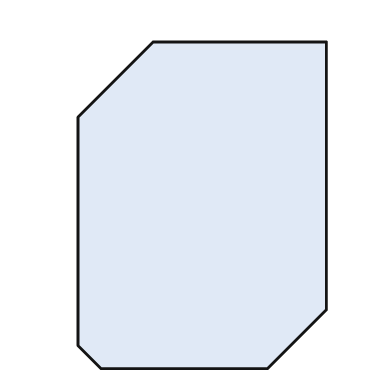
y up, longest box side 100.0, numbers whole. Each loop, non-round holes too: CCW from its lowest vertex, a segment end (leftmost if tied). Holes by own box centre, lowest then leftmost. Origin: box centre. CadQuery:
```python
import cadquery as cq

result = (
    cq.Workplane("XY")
    .moveTo(-31.0, -50.0)
    .lineTo(20.0, -50.0)
    .lineTo(38.0, -32.0)
    .lineTo(38.0, 50.0)
    .lineTo(-15.0, 50.0)
    .lineTo(-38.0, 27.0)
    .lineTo(-38.0, -43.0)
    .close()
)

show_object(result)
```